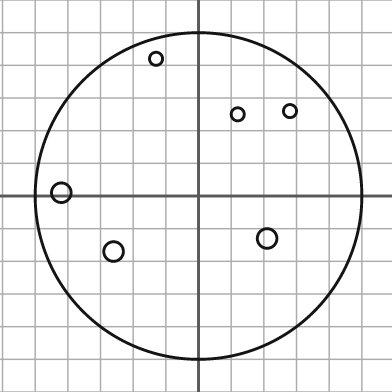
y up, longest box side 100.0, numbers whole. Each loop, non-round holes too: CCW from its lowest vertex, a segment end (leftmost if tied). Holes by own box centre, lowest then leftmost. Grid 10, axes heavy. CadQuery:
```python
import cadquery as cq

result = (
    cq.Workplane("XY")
    .moveTo(0.0, 0.0)
    .circle(50.0)
    .moveTo(-26.0, -17.0)
    .circle(3.0)
    .moveTo(21.0, -13.0)
    .circle(3.0)
    .moveTo(-42.0, 1.0)
    .circle(3.0)
    .moveTo(12.0, 25.0)
    .circle(2.0)
    .moveTo(28.0, 26.0)
    .circle(2.0)
    .moveTo(-13.0, 42.0)
    .circle(2.0)
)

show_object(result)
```